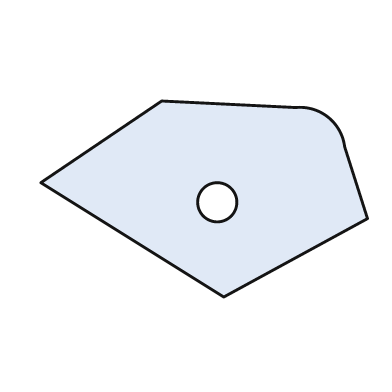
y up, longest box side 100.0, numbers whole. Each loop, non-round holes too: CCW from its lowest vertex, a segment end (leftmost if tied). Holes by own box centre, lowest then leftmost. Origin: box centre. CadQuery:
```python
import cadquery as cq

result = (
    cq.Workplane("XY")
    .moveTo(6.0, -30.0)
    .lineTo(50.0, -6.0)
    .lineTo(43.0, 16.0)
    .threePointArc((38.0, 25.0), (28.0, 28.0))
    .lineTo(-13.0, 30.0)
    .lineTo(-50.0, 5.0)
    .close()
    .moveTo(4.0, -1.0)
    .circle(6.0)
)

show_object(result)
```